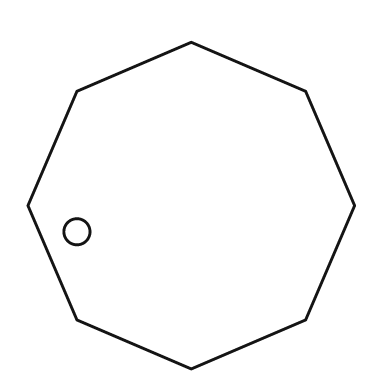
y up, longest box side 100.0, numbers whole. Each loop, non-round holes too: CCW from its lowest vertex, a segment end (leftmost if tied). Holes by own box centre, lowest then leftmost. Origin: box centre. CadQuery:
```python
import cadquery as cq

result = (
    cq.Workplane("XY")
    .moveTo(0.0, -50.0)
    .lineTo(35.0, -35.0)
    .lineTo(50.0, 0.0)
    .lineTo(35.0, 35.0)
    .lineTo(0.0, 50.0)
    .lineTo(-35.0, 35.0)
    .lineTo(-50.0, 0.0)
    .lineTo(-35.0, -35.0)
    .close()
    .moveTo(-35.0, -8.0)
    .circle(4.0)
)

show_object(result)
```